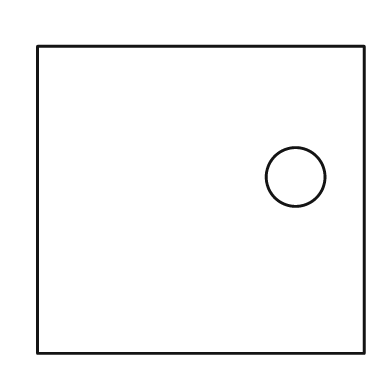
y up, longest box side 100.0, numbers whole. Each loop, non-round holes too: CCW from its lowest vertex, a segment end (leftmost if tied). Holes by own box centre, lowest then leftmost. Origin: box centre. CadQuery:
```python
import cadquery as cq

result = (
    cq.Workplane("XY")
    .moveTo(-50.0, -47.0)
    .lineTo(50.0, -47.0)
    .lineTo(50.0, 47.0)
    .lineTo(-50.0, 47.0)
    .close()
    .moveTo(29.0, 7.0)
    .circle(9.0)
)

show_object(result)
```